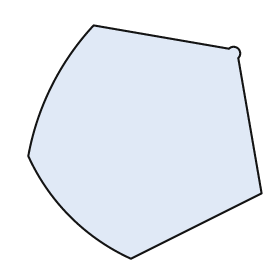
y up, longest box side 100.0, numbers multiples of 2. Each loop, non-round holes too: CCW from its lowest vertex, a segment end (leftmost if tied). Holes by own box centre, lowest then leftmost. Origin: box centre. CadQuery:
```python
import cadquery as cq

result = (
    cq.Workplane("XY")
    .moveTo(-6.0, -50.0)
    .lineTo(50.0, -22.0)
    .lineTo(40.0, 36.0)
    .threePointArc((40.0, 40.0), (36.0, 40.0))
    .lineTo(-22.0, 50.0)
    .threePointArc((-40.0, 24.0), (-50.0, -6.0))
    .threePointArc((-32.0, -32.0), (-6.0, -50.0))
    .close()
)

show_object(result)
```